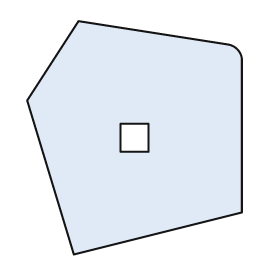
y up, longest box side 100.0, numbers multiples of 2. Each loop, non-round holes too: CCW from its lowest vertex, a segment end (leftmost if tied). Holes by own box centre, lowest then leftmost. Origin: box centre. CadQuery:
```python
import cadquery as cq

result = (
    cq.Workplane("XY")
    .moveTo(-26.0, -50.0)
    .lineTo(46.0, -32.0)
    .lineTo(46.0, 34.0)
    .threePointArc((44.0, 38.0), (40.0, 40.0))
    .lineTo(-24.0, 50.0)
    .lineTo(-46.0, 16.0)
    .close()
    .moveTo(-6.0, -6.0)
    .lineTo(6.0, -6.0)
    .lineTo(6.0, 6.0)
    .lineTo(-6.0, 6.0)
    .close()
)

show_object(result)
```